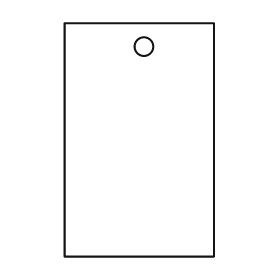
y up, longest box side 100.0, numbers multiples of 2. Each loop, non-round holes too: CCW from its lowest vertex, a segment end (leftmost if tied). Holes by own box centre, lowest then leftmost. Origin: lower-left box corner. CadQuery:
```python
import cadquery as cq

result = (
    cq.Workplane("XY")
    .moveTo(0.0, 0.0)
    .lineTo(64.0, 0.0)
    .lineTo(64.0, 100.0)
    .lineTo(0.0, 100.0)
    .close()
    .moveTo(34.0, 90.0)
    .circle(4.0)
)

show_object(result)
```